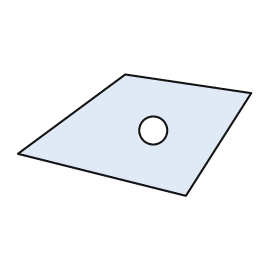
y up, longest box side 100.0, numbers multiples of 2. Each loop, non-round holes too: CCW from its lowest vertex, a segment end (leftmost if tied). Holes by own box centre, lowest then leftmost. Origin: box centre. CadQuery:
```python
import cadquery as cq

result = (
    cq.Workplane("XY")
    .moveTo(22.0, -26.0)
    .lineTo(50.0, 18.0)
    .lineTo(-4.0, 26.0)
    .lineTo(-50.0, -8.0)
    .close()
    .moveTo(8.0, 2.0)
    .circle(6.0)
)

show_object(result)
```